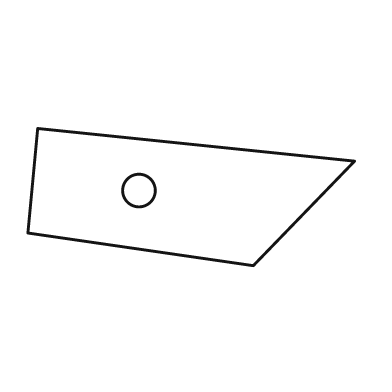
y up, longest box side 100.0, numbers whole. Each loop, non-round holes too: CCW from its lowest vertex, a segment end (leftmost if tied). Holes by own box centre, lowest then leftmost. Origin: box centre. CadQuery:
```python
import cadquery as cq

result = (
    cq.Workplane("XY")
    .moveTo(19.0, -21.0)
    .lineTo(50.0, 11.0)
    .lineTo(-47.0, 21.0)
    .lineTo(-50.0, -11.0)
    .close()
    .moveTo(-16.0, 2.0)
    .circle(5.0)
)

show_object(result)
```